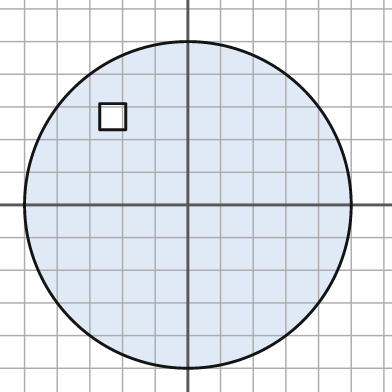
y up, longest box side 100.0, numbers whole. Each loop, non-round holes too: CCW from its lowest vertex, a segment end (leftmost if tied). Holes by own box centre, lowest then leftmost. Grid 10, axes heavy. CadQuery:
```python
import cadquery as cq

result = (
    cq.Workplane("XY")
    .moveTo(0.0, 0.0)
    .circle(50.0)
    .moveTo(-27.0, 23.0)
    .lineTo(-19.0, 23.0)
    .lineTo(-19.0, 31.0)
    .lineTo(-27.0, 31.0)
    .close()
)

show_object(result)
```